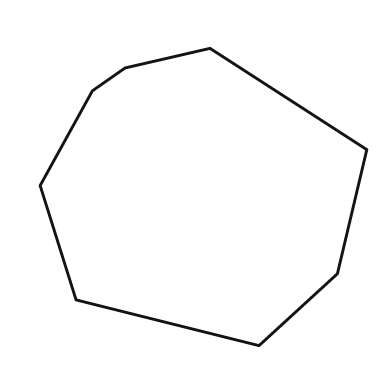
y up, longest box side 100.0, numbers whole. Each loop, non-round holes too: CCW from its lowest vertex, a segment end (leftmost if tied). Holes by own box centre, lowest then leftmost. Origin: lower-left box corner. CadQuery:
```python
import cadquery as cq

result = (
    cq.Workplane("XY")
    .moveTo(67.0, 0.0)
    .lineTo(91.0, 22.0)
    .lineTo(100.0, 60.0)
    .lineTo(52.0, 91.0)
    .lineTo(26.0, 85.0)
    .lineTo(16.0, 78.0)
    .lineTo(0.0, 49.0)
    .lineTo(11.0, 14.0)
    .close()
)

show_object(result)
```